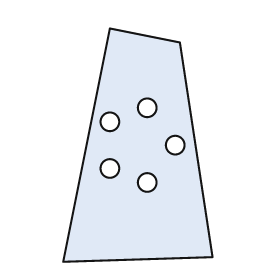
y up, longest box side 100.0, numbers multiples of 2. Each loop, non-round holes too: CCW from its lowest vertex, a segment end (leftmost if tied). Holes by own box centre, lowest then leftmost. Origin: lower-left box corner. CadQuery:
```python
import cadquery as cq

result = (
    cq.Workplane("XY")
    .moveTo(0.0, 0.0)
    .lineTo(64.0, 2.0)
    .lineTo(50.0, 94.0)
    .lineTo(20.0, 100.0)
    .close()
    .moveTo(36.0, 34.0)
    .circle(4.0)
    .moveTo(20.0, 40.0)
    .circle(4.0)
    .moveTo(48.0, 50.0)
    .circle(4.0)
    .moveTo(20.0, 60.0)
    .circle(4.0)
    .moveTo(36.0, 66.0)
    .circle(4.0)
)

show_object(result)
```